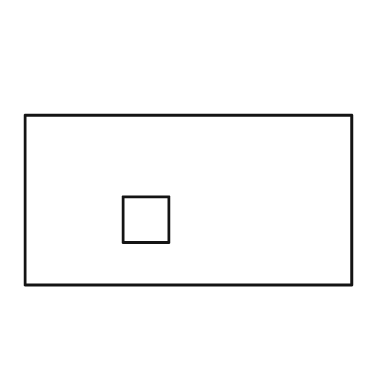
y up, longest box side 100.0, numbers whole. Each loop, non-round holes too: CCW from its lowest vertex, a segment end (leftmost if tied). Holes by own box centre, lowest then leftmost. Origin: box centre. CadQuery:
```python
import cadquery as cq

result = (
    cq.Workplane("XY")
    .moveTo(-50.0, -26.0)
    .lineTo(50.0, -26.0)
    .lineTo(50.0, 26.0)
    .lineTo(-50.0, 26.0)
    .close()
    .moveTo(-20.0, -13.0)
    .lineTo(-6.0, -13.0)
    .lineTo(-6.0, 1.0)
    .lineTo(-20.0, 1.0)
    .close()
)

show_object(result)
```